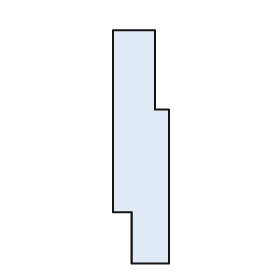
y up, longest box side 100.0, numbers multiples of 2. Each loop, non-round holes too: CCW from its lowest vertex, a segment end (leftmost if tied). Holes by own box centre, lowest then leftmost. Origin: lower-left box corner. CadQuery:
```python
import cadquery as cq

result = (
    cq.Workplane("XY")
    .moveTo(8.0, 0.0)
    .lineTo(24.0, 0.0)
    .lineTo(24.0, 66.0)
    .lineTo(18.0, 66.0)
    .lineTo(18.0, 100.0)
    .lineTo(0.0, 100.0)
    .lineTo(0.0, 22.0)
    .lineTo(8.0, 22.0)
    .close()
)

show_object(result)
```